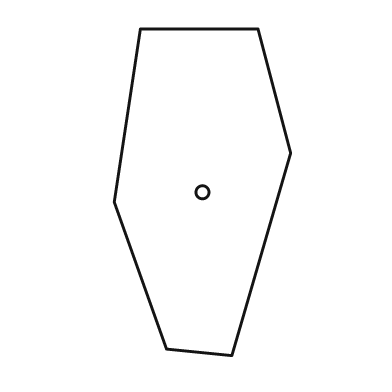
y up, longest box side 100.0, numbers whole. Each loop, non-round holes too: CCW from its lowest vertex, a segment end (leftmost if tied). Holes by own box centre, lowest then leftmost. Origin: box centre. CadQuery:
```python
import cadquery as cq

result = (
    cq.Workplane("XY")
    .moveTo(9.0, -50.0)
    .lineTo(27.0, 12.0)
    .lineTo(17.0, 50.0)
    .lineTo(-19.0, 50.0)
    .lineTo(-27.0, -3.0)
    .lineTo(-11.0, -48.0)
    .close()
    .moveTo(0.0, 0.0)
    .circle(2.0)
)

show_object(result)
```